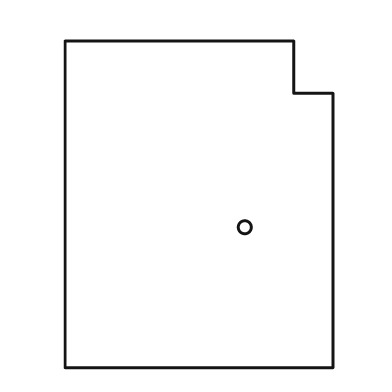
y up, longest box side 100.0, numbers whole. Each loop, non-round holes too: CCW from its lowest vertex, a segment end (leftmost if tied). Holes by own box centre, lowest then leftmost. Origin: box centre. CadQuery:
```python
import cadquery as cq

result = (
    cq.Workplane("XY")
    .moveTo(-41.0, -50.0)
    .lineTo(41.0, -50.0)
    .lineTo(41.0, 34.0)
    .lineTo(29.0, 34.0)
    .lineTo(29.0, 50.0)
    .lineTo(-41.0, 50.0)
    .close()
    .moveTo(14.0, -7.0)
    .circle(2.0)
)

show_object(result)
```